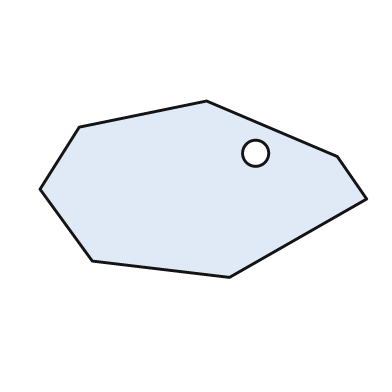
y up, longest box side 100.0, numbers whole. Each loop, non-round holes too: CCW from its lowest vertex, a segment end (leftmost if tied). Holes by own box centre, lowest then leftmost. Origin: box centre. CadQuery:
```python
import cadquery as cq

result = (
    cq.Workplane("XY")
    .moveTo(8.0, -27.0)
    .lineTo(50.0, -3.0)
    .lineTo(41.0, 10.0)
    .lineTo(1.0, 27.0)
    .lineTo(-38.0, 19.0)
    .lineTo(-50.0, 0.0)
    .lineTo(-34.0, -22.0)
    .close()
    .moveTo(16.0, 11.0)
    .circle(4.0)
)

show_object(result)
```